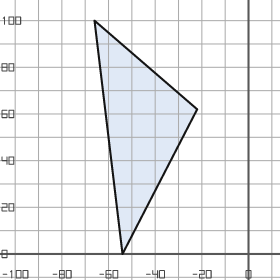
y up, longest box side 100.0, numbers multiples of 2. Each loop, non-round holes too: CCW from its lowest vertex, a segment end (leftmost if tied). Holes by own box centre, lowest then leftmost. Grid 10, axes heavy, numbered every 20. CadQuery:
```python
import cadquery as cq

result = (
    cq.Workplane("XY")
    .moveTo(-54.0, 0.0)
    .lineTo(-22.0, 62.0)
    .lineTo(-66.0, 100.0)
    .close()
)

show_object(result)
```